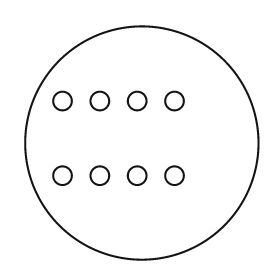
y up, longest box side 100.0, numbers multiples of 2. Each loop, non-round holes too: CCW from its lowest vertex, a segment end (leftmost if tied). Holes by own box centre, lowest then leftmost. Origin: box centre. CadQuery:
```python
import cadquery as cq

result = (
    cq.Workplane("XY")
    .moveTo(0.0, 0.0)
    .circle(50.0)
    .moveTo(-34.0, -14.0)
    .circle(4.0)
    .moveTo(-18.0, -14.0)
    .circle(4.0)
    .moveTo(-2.0, -14.0)
    .circle(4.0)
    .moveTo(14.0, -14.0)
    .circle(4.0)
    .moveTo(-34.0, 18.0)
    .circle(4.0)
    .moveTo(-18.0, 18.0)
    .circle(4.0)
    .moveTo(-2.0, 18.0)
    .circle(4.0)
    .moveTo(14.0, 18.0)
    .circle(4.0)
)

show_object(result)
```